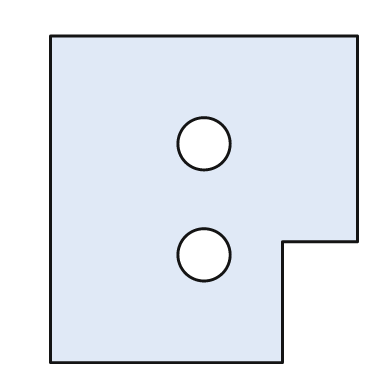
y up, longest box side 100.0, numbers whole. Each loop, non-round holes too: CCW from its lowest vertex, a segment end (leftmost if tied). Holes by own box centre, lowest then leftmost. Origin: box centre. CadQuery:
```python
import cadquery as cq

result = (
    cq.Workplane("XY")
    .moveTo(-47.0, -50.0)
    .lineTo(24.0, -50.0)
    .lineTo(24.0, -13.0)
    .lineTo(47.0, -13.0)
    .lineTo(47.0, 50.0)
    .lineTo(-47.0, 50.0)
    .close()
    .moveTo(0.0, -17.0)
    .circle(8.0)
    .moveTo(0.0, 17.0)
    .circle(8.0)
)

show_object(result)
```